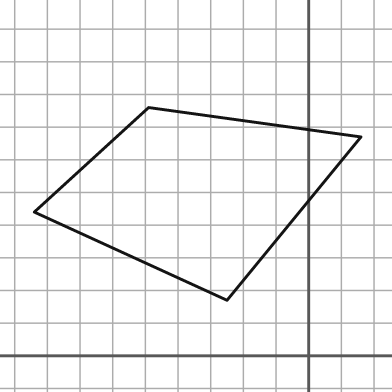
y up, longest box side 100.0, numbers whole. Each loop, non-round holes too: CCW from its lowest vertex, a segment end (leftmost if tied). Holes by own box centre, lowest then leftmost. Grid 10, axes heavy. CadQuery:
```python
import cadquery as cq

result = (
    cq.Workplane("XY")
    .moveTo(-25.0, 17.0)
    .lineTo(16.0, 67.0)
    .lineTo(-49.0, 76.0)
    .lineTo(-84.0, 44.0)
    .close()
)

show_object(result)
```